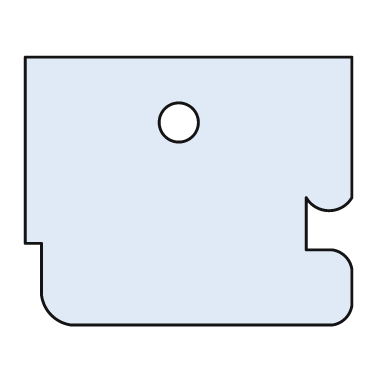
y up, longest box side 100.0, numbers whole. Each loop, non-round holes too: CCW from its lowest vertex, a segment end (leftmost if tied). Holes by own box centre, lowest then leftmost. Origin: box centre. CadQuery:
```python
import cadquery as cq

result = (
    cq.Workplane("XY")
    .moveTo(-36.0, -41.0)
    .lineTo(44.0, -41.0)
    .threePointArc((48.0, -39.0), (50.0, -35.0))
    .lineTo(50.0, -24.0)
    .threePointArc((48.0, -20.0), (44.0, -18.0))
    .lineTo(36.0, -18.0)
    .lineTo(36.0, -2.0)
    .threePointArc((43.0, -6.0), (50.0, -2.0))
    .lineTo(50.0, 41.0)
    .lineTo(-50.0, 41.0)
    .lineTo(-50.0, -16.0)
    .lineTo(-45.0, -16.0)
    .lineTo(-45.0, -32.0)
    .threePointArc((-42.0, -38.0), (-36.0, -41.0))
    .close()
    .moveTo(-3.0, 21.0)
    .circle(6.0)
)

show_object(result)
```